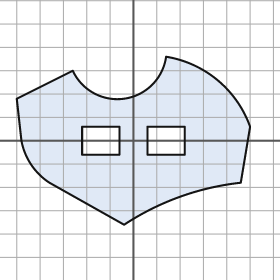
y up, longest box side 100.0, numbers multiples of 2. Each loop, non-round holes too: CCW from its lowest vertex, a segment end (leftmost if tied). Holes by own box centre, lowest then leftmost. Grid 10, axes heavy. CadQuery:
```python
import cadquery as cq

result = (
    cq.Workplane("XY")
    .moveTo(-4.0, -36.0)
    .threePointArc((20.0, -24.0), (46.0, -18.0))
    .lineTo(50.0, 6.0)
    .threePointArc((36.0, 26.0), (14.0, 36.0))
    .threePointArc((-4.0, 18.0), (-26.0, 30.0))
    .lineTo(-50.0, 18.0)
    .lineTo(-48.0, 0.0)
    .threePointArc((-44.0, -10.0), (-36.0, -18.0))
    .close()
    .moveTo(-22.0, -6.0)
    .lineTo(-6.0, -6.0)
    .lineTo(-6.0, 6.0)
    .lineTo(-22.0, 6.0)
    .close()
    .moveTo(6.0, -6.0)
    .lineTo(22.0, -6.0)
    .lineTo(22.0, 6.0)
    .lineTo(6.0, 6.0)
    .close()
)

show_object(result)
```